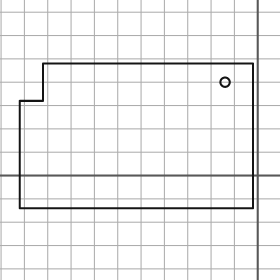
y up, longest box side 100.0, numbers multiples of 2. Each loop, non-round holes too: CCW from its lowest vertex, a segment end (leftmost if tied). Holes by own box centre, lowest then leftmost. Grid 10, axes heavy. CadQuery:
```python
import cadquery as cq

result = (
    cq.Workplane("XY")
    .moveTo(-102.0, -14.0)
    .lineTo(-2.0, -14.0)
    .lineTo(-2.0, 48.0)
    .lineTo(-92.0, 48.0)
    .lineTo(-92.0, 32.0)
    .lineTo(-102.0, 32.0)
    .close()
    .moveTo(-14.0, 40.0)
    .circle(2.0)
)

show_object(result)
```